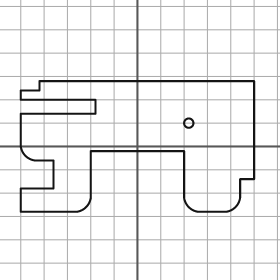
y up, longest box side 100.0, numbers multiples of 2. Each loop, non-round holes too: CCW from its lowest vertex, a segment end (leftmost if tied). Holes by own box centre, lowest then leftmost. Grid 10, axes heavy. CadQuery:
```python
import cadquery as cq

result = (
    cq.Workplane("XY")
    .moveTo(-50.0, -28.0)
    .lineTo(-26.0, -28.0)
    .threePointArc((-22.0, -26.0), (-20.0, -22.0))
    .lineTo(-20.0, -2.0)
    .lineTo(20.0, -2.0)
    .lineTo(20.0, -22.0)
    .threePointArc((22.0, -26.0), (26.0, -28.0))
    .lineTo(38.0, -28.0)
    .threePointArc((42.0, -26.0), (44.0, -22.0))
    .lineTo(44.0, -14.0)
    .lineTo(50.0, -14.0)
    .lineTo(50.0, 28.0)
    .lineTo(-42.0, 28.0)
    .lineTo(-42.0, 24.0)
    .lineTo(-50.0, 24.0)
    .lineTo(-50.0, 20.0)
    .lineTo(-18.0, 20.0)
    .lineTo(-18.0, 14.0)
    .lineTo(-50.0, 14.0)
    .lineTo(-50.0, 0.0)
    .threePointArc((-48.0, -4.0), (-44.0, -6.0))
    .lineTo(-36.0, -6.0)
    .lineTo(-36.0, -18.0)
    .lineTo(-50.0, -18.0)
    .close()
    .moveTo(22.0, 10.0)
    .circle(2.0)
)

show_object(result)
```